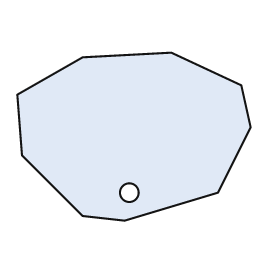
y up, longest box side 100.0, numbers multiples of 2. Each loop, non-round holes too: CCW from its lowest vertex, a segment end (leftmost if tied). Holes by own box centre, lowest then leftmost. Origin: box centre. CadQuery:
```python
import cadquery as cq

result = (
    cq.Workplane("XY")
    .moveTo(-4.0, -36.0)
    .lineTo(36.0, -24.0)
    .lineTo(50.0, 4.0)
    .lineTo(46.0, 22.0)
    .lineTo(16.0, 36.0)
    .lineTo(-22.0, 34.0)
    .lineTo(-50.0, 18.0)
    .lineTo(-48.0, -8.0)
    .lineTo(-22.0, -34.0)
    .close()
    .moveTo(-2.0, -24.0)
    .circle(4.0)
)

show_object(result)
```